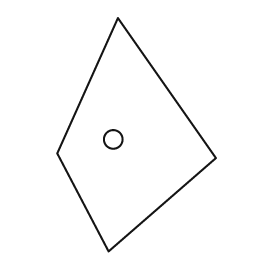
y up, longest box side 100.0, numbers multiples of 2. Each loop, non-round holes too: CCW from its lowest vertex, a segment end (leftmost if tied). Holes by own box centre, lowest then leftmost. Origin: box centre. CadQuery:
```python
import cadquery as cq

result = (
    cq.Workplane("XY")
    .moveTo(-12.0, -50.0)
    .lineTo(34.0, -10.0)
    .lineTo(-8.0, 50.0)
    .lineTo(-34.0, -8.0)
    .close()
    .moveTo(-10.0, -2.0)
    .circle(4.0)
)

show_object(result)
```